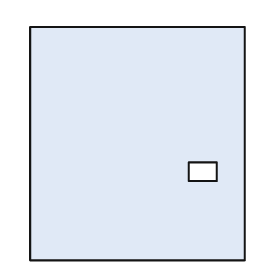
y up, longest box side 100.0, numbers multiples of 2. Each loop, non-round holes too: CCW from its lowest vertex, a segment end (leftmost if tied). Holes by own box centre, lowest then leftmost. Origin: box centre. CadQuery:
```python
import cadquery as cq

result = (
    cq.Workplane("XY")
    .moveTo(-46.0, -50.0)
    .lineTo(46.0, -50.0)
    .lineTo(46.0, 50.0)
    .lineTo(-46.0, 50.0)
    .close()
    .moveTo(22.0, -16.0)
    .lineTo(34.0, -16.0)
    .lineTo(34.0, -8.0)
    .lineTo(22.0, -8.0)
    .close()
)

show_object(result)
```